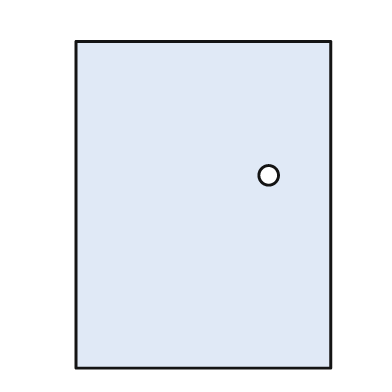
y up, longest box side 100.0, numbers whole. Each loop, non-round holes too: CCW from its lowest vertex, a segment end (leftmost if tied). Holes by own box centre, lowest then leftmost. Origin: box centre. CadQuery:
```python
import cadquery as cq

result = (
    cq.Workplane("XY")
    .moveTo(-39.0, -50.0)
    .lineTo(39.0, -50.0)
    .lineTo(39.0, 50.0)
    .lineTo(-39.0, 50.0)
    .close()
    .moveTo(20.0, 9.0)
    .circle(3.0)
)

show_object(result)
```